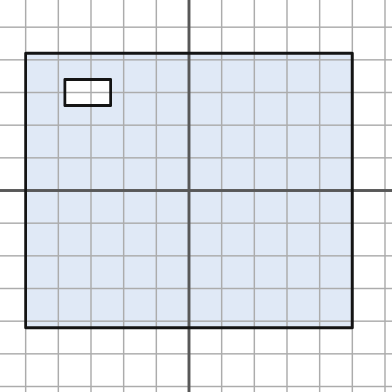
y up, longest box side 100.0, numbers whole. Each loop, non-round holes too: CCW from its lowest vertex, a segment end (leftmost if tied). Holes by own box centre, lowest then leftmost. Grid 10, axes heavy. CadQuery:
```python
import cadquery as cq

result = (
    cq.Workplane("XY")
    .moveTo(-50.0, -42.0)
    .lineTo(50.0, -42.0)
    .lineTo(50.0, 42.0)
    .lineTo(-50.0, 42.0)
    .close()
    .moveTo(-38.0, 26.0)
    .lineTo(-24.0, 26.0)
    .lineTo(-24.0, 34.0)
    .lineTo(-38.0, 34.0)
    .close()
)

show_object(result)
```